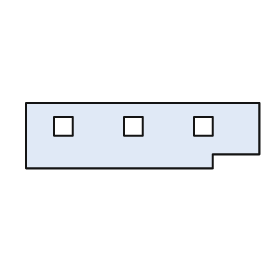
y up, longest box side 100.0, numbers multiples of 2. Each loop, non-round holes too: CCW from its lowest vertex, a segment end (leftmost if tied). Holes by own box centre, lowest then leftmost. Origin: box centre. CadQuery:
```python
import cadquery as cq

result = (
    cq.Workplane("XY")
    .moveTo(-50.0, -14.0)
    .lineTo(30.0, -14.0)
    .lineTo(30.0, -8.0)
    .lineTo(50.0, -8.0)
    .lineTo(50.0, 14.0)
    .lineTo(-50.0, 14.0)
    .close()
    .moveTo(-38.0, 0.0)
    .lineTo(-30.0, 0.0)
    .lineTo(-30.0, 8.0)
    .lineTo(-38.0, 8.0)
    .close()
    .moveTo(-8.0, 0.0)
    .lineTo(0.0, 0.0)
    .lineTo(0.0, 8.0)
    .lineTo(-8.0, 8.0)
    .close()
    .moveTo(22.0, 0.0)
    .lineTo(30.0, 0.0)
    .lineTo(30.0, 8.0)
    .lineTo(22.0, 8.0)
    .close()
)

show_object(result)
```